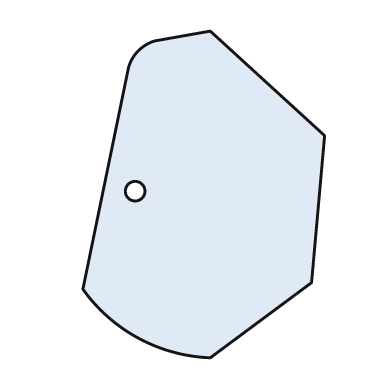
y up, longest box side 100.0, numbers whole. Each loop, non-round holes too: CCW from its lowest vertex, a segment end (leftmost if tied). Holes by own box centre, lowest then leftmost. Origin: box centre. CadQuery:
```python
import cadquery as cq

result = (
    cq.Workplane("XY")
    .moveTo(2.0, -50.0)
    .lineTo(33.0, -27.0)
    .lineTo(37.0, 18.0)
    .lineTo(2.0, 50.0)
    .lineTo(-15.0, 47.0)
    .threePointArc((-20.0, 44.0), (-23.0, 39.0))
    .lineTo(-37.0, -29.0)
    .threePointArc((-20.0, -44.0), (2.0, -50.0))
    .close()
    .moveTo(-21.0, 1.0)
    .circle(3.0)
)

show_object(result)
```